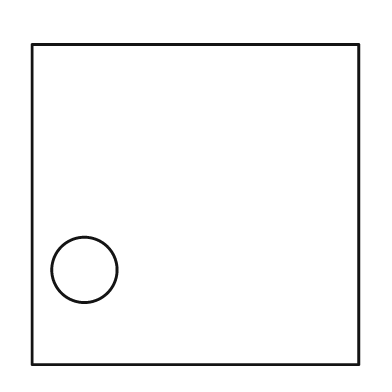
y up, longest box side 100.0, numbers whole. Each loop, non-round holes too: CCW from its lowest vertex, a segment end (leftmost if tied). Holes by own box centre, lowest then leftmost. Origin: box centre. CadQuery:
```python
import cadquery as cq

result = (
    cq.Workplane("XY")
    .moveTo(-50.0, -49.0)
    .lineTo(50.0, -49.0)
    .lineTo(50.0, 49.0)
    .lineTo(-50.0, 49.0)
    .close()
    .moveTo(-34.0, -20.0)
    .circle(10.0)
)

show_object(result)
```